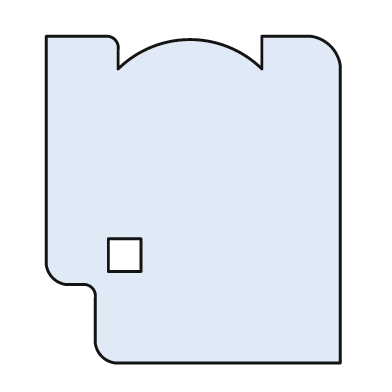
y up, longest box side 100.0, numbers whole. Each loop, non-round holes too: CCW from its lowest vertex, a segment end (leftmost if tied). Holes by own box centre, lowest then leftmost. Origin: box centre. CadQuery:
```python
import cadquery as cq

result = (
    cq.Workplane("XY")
    .moveTo(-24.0, -50.0)
    .lineTo(45.0, -50.0)
    .lineTo(45.0, 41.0)
    .threePointArc((42.0, 47.0), (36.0, 50.0))
    .lineTo(21.0, 50.0)
    .lineTo(21.0, 40.0)
    .threePointArc((-1.0, 49.0), (-23.0, 40.0))
    .lineTo(-23.0, 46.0)
    .threePointArc((-24.0, 49.0), (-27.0, 50.0))
    .lineTo(-45.0, 50.0)
    .lineTo(-45.0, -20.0)
    .threePointArc((-43.0, -24.0), (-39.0, -26.0))
    .lineTo(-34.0, -26.0)
    .threePointArc((-31.0, -27.0), (-30.0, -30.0))
    .lineTo(-30.0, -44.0)
    .threePointArc((-28.0, -48.0), (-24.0, -50.0))
    .close()
    .moveTo(-26.0, -22.0)
    .lineTo(-16.0, -22.0)
    .lineTo(-16.0, -12.0)
    .lineTo(-26.0, -12.0)
    .close()
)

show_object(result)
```